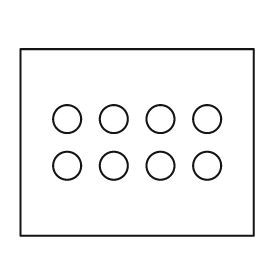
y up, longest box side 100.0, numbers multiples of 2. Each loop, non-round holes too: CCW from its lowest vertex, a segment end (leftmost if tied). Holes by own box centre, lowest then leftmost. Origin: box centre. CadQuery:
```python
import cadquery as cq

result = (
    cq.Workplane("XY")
    .moveTo(-50.0, -40.0)
    .lineTo(50.0, -40.0)
    .lineTo(50.0, 40.0)
    .lineTo(-50.0, 40.0)
    .close()
    .moveTo(-30.0, -10.0)
    .circle(6.0)
    .moveTo(-10.0, -10.0)
    .circle(6.0)
    .moveTo(10.0, -10.0)
    .circle(6.0)
    .moveTo(30.0, -10.0)
    .circle(6.0)
    .moveTo(-30.0, 10.0)
    .circle(6.0)
    .moveTo(-10.0, 10.0)
    .circle(6.0)
    .moveTo(10.0, 10.0)
    .circle(6.0)
    .moveTo(30.0, 10.0)
    .circle(6.0)
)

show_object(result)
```